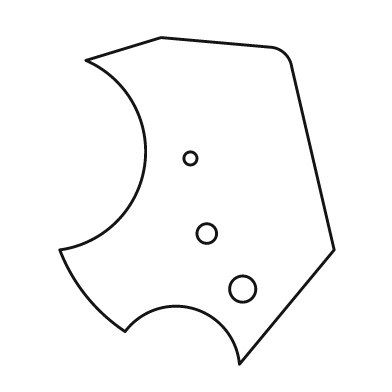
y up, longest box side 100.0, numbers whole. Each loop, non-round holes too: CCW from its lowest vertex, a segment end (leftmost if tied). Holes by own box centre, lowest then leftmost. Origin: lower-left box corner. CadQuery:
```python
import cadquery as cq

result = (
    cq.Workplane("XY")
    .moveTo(55.0, 0.0)
    .lineTo(84.0, 35.0)
    .lineTo(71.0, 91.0)
    .threePointArc((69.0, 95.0), (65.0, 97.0))
    .lineTo(31.0, 100.0)
    .lineTo(8.0, 93.0)
    .threePointArc((26.0, 61.0), (0.0, 35.0))
    .threePointArc((8.0, 21.0), (20.0, 10.0))
    .threePointArc((41.0, 17.0), (55.0, 0.0))
    .close()
    .moveTo(56.0, 23.0)
    .circle(4.0)
    .moveTo(45.0, 40.0)
    .circle(3.0)
    .moveTo(40.0, 63.0)
    .circle(2.0)
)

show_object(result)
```